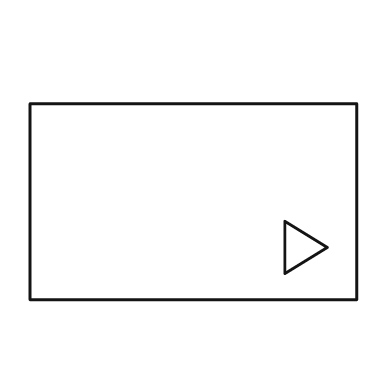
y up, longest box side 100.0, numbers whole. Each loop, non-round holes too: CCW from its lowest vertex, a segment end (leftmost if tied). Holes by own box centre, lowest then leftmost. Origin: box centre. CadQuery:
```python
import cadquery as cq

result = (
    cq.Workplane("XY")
    .moveTo(-50.0, -30.0)
    .lineTo(50.0, -30.0)
    .lineTo(50.0, 30.0)
    .lineTo(-50.0, 30.0)
    .close()
    .moveTo(28.0, -22.0)
    .lineTo(41.0, -14.0)
    .lineTo(28.0, -6.0)
    .close()
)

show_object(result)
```